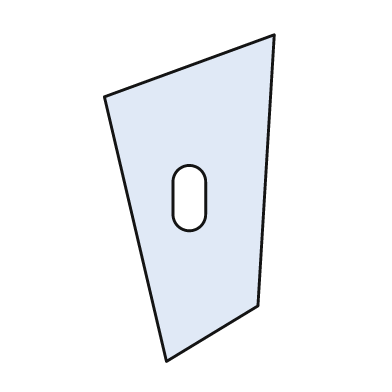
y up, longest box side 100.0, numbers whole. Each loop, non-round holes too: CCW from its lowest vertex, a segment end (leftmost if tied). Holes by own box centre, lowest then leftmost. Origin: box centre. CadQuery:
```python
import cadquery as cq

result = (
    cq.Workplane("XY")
    .moveTo(-7.0, -50.0)
    .lineTo(21.0, -33.0)
    .lineTo(26.0, 50.0)
    .lineTo(-26.0, 31.0)
    .close()
    .moveTo(-5.0, -5.0)
    .threePointArc((0.0, -10.0), (5.0, -5.0))
    .lineTo(5.0, 5.0)
    .threePointArc((0.0, 10.0), (-5.0, 5.0))
    .close()
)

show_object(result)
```